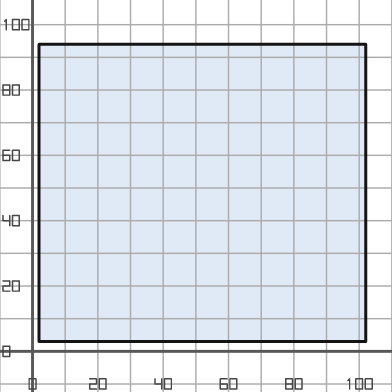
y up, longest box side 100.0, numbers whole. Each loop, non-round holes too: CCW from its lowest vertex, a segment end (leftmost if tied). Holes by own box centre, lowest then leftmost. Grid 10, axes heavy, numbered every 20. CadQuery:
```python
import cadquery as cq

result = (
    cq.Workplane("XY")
    .moveTo(2.0, 3.0)
    .lineTo(102.0, 3.0)
    .lineTo(102.0, 94.0)
    .lineTo(2.0, 94.0)
    .close()
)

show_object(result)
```